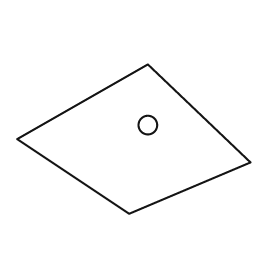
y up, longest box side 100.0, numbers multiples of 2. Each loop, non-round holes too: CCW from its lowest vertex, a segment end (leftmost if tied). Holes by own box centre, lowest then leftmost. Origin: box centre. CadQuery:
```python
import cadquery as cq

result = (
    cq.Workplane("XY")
    .moveTo(-2.0, -32.0)
    .lineTo(50.0, -10.0)
    .lineTo(6.0, 32.0)
    .lineTo(-50.0, 0.0)
    .close()
    .moveTo(6.0, 6.0)
    .circle(4.0)
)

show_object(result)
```